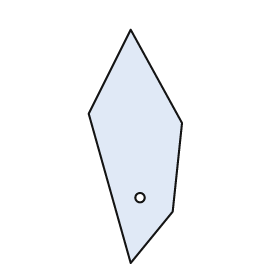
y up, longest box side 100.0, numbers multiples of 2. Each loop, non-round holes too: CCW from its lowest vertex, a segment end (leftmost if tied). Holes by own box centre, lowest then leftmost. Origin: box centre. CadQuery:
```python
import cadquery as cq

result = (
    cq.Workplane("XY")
    .moveTo(-2.0, -50.0)
    .lineTo(16.0, -28.0)
    .lineTo(20.0, 10.0)
    .lineTo(-2.0, 50.0)
    .lineTo(-20.0, 14.0)
    .close()
    .moveTo(2.0, -22.0)
    .circle(2.0)
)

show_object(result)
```